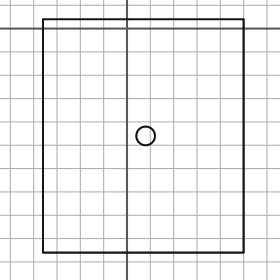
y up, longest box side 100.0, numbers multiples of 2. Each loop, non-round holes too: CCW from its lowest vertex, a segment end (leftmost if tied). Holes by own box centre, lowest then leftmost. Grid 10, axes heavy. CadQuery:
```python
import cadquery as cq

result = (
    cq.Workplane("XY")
    .moveTo(-36.0, -96.0)
    .lineTo(50.0, -96.0)
    .lineTo(50.0, 4.0)
    .lineTo(-36.0, 4.0)
    .close()
    .moveTo(8.0, -46.0)
    .circle(4.0)
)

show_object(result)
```